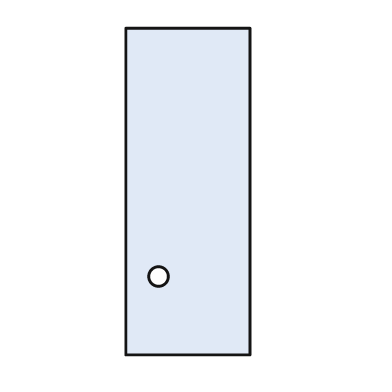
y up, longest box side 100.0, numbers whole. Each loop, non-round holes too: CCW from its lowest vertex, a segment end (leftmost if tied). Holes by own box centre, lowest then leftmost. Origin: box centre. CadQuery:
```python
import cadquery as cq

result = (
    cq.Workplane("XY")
    .moveTo(-19.0, -50.0)
    .lineTo(19.0, -50.0)
    .lineTo(19.0, 50.0)
    .lineTo(-19.0, 50.0)
    .close()
    .moveTo(-9.0, -26.0)
    .circle(3.0)
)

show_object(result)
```